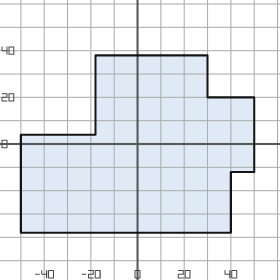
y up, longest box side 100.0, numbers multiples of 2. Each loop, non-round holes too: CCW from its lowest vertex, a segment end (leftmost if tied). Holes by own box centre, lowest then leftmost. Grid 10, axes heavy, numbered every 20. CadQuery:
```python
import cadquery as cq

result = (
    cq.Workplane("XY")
    .moveTo(-50.0, -38.0)
    .lineTo(40.0, -38.0)
    .lineTo(40.0, -12.0)
    .lineTo(50.0, -12.0)
    .lineTo(50.0, 20.0)
    .lineTo(30.0, 20.0)
    .lineTo(30.0, 38.0)
    .lineTo(-18.0, 38.0)
    .lineTo(-18.0, 4.0)
    .lineTo(-50.0, 4.0)
    .close()
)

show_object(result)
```